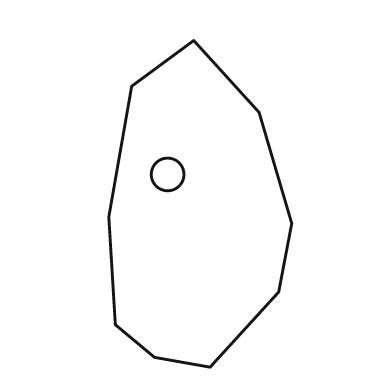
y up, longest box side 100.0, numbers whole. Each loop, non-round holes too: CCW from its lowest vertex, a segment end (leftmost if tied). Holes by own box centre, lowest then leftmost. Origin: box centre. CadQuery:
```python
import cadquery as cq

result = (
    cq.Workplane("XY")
    .moveTo(3.0, -50.0)
    .lineTo(24.0, -27.0)
    .lineTo(28.0, -6.0)
    .lineTo(18.0, 28.0)
    .lineTo(-2.0, 50.0)
    .lineTo(-21.0, 36.0)
    .lineTo(-28.0, -4.0)
    .lineTo(-26.0, -37.0)
    .lineTo(-14.0, -47.0)
    .close()
    .moveTo(-10.0, 9.0)
    .circle(5.0)
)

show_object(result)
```